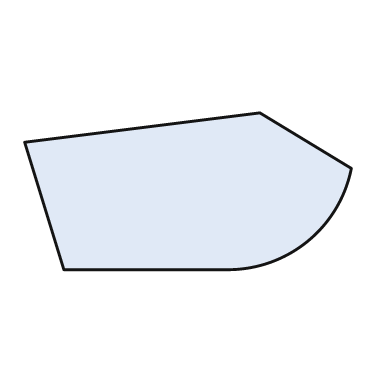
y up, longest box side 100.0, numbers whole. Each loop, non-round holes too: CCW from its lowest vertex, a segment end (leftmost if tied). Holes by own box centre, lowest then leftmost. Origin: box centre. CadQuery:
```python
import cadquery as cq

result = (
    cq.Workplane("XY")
    .moveTo(-38.0, -24.0)
    .lineTo(13.0, -24.0)
    .threePointArc((37.0, -15.0), (50.0, 7.0))
    .lineTo(22.0, 24.0)
    .lineTo(-50.0, 15.0)
    .close()
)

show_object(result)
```